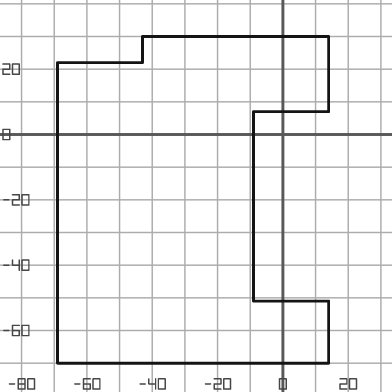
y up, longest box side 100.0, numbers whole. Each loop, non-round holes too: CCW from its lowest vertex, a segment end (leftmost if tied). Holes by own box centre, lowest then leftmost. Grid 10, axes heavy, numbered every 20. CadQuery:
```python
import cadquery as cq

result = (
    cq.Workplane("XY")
    .moveTo(-69.0, -70.0)
    .lineTo(14.0, -70.0)
    .lineTo(14.0, -51.0)
    .lineTo(-9.0, -51.0)
    .lineTo(-9.0, 7.0)
    .lineTo(14.0, 7.0)
    .lineTo(14.0, 30.0)
    .lineTo(-43.0, 30.0)
    .lineTo(-43.0, 22.0)
    .lineTo(-69.0, 22.0)
    .close()
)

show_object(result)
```